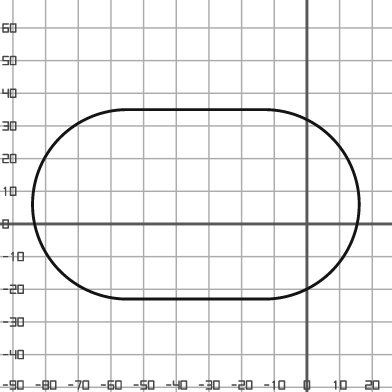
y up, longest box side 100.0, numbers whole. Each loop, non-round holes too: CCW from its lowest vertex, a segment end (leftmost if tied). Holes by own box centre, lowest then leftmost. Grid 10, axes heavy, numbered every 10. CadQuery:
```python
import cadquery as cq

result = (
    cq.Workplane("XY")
    .moveTo(-55.0, -23.0)
    .lineTo(-13.0, -23.0)
    .threePointArc((16.0, 6.0), (-13.0, 35.0))
    .lineTo(-55.0, 35.0)
    .threePointArc((-84.0, 6.0), (-55.0, -23.0))
    .close()
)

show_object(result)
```